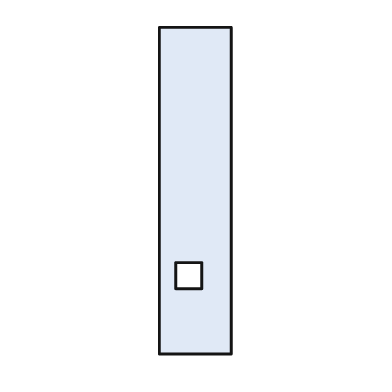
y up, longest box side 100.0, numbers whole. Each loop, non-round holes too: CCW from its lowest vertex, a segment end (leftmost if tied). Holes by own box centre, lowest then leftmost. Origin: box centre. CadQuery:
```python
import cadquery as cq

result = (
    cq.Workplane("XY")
    .moveTo(-11.0, -50.0)
    .lineTo(11.0, -50.0)
    .lineTo(11.0, 50.0)
    .lineTo(-11.0, 50.0)
    .close()
    .moveTo(-6.0, -30.0)
    .lineTo(2.0, -30.0)
    .lineTo(2.0, -22.0)
    .lineTo(-6.0, -22.0)
    .close()
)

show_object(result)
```